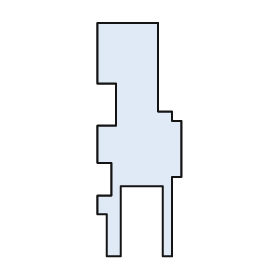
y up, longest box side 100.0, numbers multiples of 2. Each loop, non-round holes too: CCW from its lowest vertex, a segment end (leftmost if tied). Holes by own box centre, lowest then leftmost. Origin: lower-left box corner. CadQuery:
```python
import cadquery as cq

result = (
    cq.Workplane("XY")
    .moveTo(4.0, 0.0)
    .lineTo(10.0, 0.0)
    .lineTo(10.0, 30.0)
    .lineTo(28.0, 30.0)
    .lineTo(28.0, 0.0)
    .lineTo(32.0, 0.0)
    .lineTo(32.0, 34.0)
    .lineTo(36.0, 34.0)
    .lineTo(36.0, 58.0)
    .lineTo(32.0, 58.0)
    .lineTo(32.0, 62.0)
    .lineTo(26.0, 62.0)
    .lineTo(26.0, 100.0)
    .lineTo(0.0, 100.0)
    .lineTo(0.0, 74.0)
    .lineTo(8.0, 74.0)
    .lineTo(8.0, 56.0)
    .lineTo(0.0, 56.0)
    .lineTo(0.0, 40.0)
    .lineTo(6.0, 40.0)
    .lineTo(6.0, 26.0)
    .lineTo(0.0, 26.0)
    .lineTo(0.0, 18.0)
    .lineTo(4.0, 18.0)
    .close()
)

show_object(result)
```